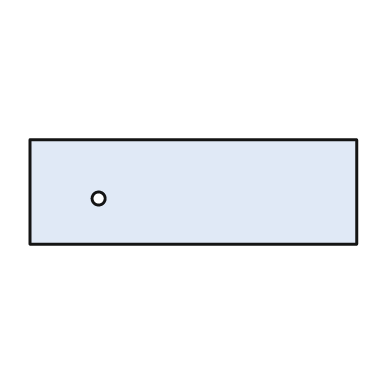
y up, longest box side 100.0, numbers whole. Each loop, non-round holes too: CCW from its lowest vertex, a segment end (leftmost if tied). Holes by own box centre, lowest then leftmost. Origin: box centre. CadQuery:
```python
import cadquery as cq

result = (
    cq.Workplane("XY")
    .moveTo(-50.0, -16.0)
    .lineTo(50.0, -16.0)
    .lineTo(50.0, 16.0)
    .lineTo(-50.0, 16.0)
    .close()
    .moveTo(-29.0, -2.0)
    .circle(2.0)
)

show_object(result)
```